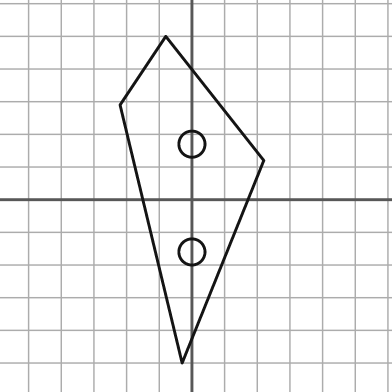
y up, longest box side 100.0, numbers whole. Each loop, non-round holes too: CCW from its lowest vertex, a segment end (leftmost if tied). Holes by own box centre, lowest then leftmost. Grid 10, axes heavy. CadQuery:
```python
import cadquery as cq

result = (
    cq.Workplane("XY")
    .moveTo(-3.0, -50.0)
    .lineTo(22.0, 12.0)
    .lineTo(-8.0, 50.0)
    .lineTo(-22.0, 29.0)
    .close()
    .moveTo(0.0, -16.0)
    .circle(4.0)
    .moveTo(0.0, 17.0)
    .circle(4.0)
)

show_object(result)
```